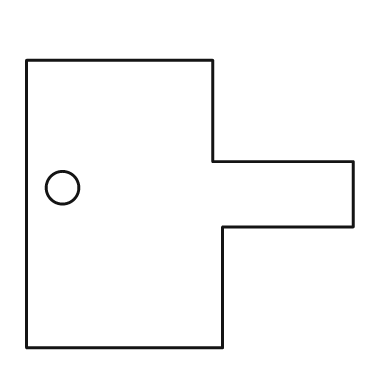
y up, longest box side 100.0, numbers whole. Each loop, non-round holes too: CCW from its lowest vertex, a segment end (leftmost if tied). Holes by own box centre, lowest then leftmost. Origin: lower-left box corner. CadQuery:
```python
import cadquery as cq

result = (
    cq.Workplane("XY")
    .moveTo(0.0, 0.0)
    .lineTo(60.0, 0.0)
    .lineTo(60.0, 37.0)
    .lineTo(100.0, 37.0)
    .lineTo(100.0, 57.0)
    .lineTo(57.0, 57.0)
    .lineTo(57.0, 88.0)
    .lineTo(0.0, 88.0)
    .close()
    .moveTo(11.0, 49.0)
    .circle(5.0)
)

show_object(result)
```